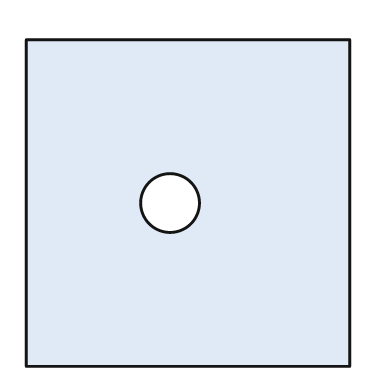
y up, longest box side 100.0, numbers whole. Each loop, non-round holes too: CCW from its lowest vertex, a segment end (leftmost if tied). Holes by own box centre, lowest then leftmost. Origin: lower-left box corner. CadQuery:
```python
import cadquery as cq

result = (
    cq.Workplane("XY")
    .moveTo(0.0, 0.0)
    .lineTo(99.0, 0.0)
    .lineTo(99.0, 100.0)
    .lineTo(0.0, 100.0)
    .close()
    .moveTo(44.0, 50.0)
    .circle(9.0)
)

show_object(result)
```